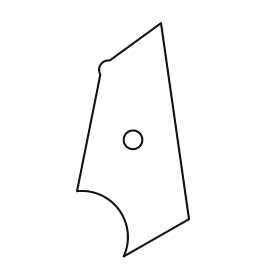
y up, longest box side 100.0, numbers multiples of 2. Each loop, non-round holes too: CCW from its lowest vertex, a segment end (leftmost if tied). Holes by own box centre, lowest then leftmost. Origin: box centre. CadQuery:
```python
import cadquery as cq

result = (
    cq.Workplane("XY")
    .moveTo(-4.0, -50.0)
    .lineTo(24.0, -34.0)
    .lineTo(12.0, 50.0)
    .lineTo(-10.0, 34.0)
    .threePointArc((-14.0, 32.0), (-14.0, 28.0))
    .lineTo(-24.0, -22.0)
    .threePointArc((-6.0, -30.0), (-4.0, -50.0))
    .close()
    .moveTo(0.0, 0.0)
    .circle(4.0)
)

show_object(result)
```